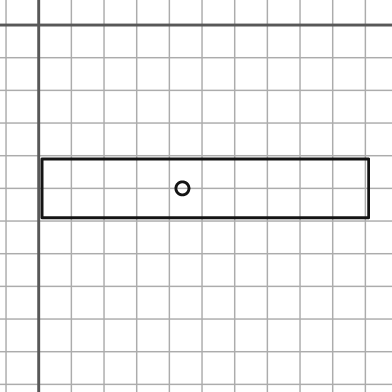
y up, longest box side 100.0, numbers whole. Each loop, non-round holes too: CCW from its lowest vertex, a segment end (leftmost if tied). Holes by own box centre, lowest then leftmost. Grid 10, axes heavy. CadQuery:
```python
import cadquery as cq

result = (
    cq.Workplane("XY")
    .moveTo(1.0, -59.0)
    .lineTo(101.0, -59.0)
    .lineTo(101.0, -41.0)
    .lineTo(1.0, -41.0)
    .close()
    .moveTo(44.0, -50.0)
    .circle(2.0)
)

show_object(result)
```